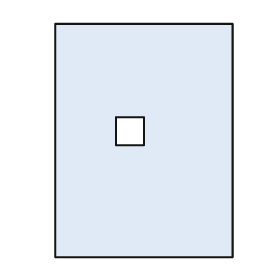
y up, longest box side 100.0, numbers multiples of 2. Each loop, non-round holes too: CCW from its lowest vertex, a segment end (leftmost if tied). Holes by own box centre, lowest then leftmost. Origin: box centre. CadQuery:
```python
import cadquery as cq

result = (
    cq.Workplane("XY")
    .moveTo(-38.0, -50.0)
    .lineTo(38.0, -50.0)
    .lineTo(38.0, 50.0)
    .lineTo(-38.0, 50.0)
    .close()
    .moveTo(-12.0, -2.0)
    .lineTo(0.0, -2.0)
    .lineTo(0.0, 10.0)
    .lineTo(-12.0, 10.0)
    .close()
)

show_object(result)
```